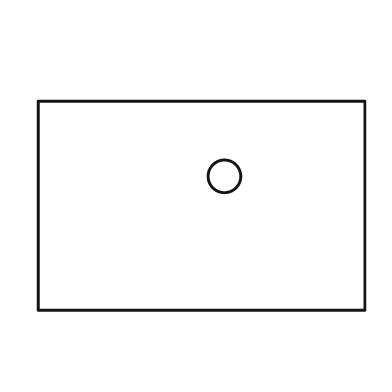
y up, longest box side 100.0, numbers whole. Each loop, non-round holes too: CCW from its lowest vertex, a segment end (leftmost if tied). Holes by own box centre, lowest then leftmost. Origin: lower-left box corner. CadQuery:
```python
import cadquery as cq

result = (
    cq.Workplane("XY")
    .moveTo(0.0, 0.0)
    .lineTo(100.0, 0.0)
    .lineTo(100.0, 64.0)
    .lineTo(0.0, 64.0)
    .close()
    .moveTo(57.0, 41.0)
    .circle(5.0)
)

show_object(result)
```